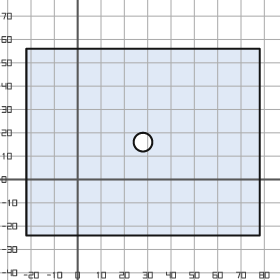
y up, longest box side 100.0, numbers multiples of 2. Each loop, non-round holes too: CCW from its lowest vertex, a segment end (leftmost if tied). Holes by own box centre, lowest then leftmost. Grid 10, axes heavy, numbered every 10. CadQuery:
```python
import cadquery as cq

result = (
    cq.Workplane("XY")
    .moveTo(-22.0, -24.0)
    .lineTo(78.0, -24.0)
    .lineTo(78.0, 56.0)
    .lineTo(-22.0, 56.0)
    .close()
    .moveTo(28.0, 16.0)
    .circle(4.0)
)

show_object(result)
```